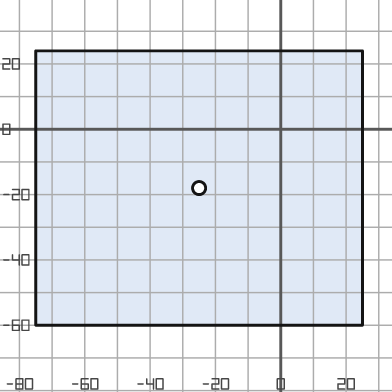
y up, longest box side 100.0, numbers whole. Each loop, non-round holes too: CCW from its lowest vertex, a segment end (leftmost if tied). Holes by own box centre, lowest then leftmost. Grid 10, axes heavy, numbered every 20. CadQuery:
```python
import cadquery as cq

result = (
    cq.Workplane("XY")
    .moveTo(-75.0, -60.0)
    .lineTo(25.0, -60.0)
    .lineTo(25.0, 24.0)
    .lineTo(-75.0, 24.0)
    .close()
    .moveTo(-25.0, -18.0)
    .circle(2.0)
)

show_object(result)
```